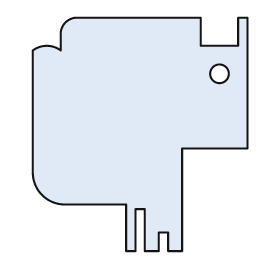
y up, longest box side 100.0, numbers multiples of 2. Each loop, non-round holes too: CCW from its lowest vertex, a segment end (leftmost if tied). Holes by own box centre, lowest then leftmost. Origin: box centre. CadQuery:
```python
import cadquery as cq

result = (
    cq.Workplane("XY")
    .moveTo(-6.0, -50.0)
    .lineTo(-2.0, -50.0)
    .lineTo(-2.0, -32.0)
    .lineTo(2.0, -32.0)
    .lineTo(2.0, -50.0)
    .lineTo(8.0, -50.0)
    .lineTo(8.0, -42.0)
    .lineTo(12.0, -42.0)
    .lineTo(12.0, -50.0)
    .lineTo(18.0, -50.0)
    .lineTo(18.0, -6.0)
    .lineTo(46.0, -6.0)
    .lineTo(46.0, 50.0)
    .lineTo(42.0, 50.0)
    .lineTo(42.0, 38.0)
    .lineTo(26.0, 38.0)
    .lineTo(26.0, 50.0)
    .lineTo(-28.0, 50.0)
    .threePointArc((-32.0, 48.0), (-34.0, 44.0))
    .lineTo(-34.0, 36.0)
    .threePointArc((-40.0, 38.0), (-46.0, 36.0))
    .lineTo(-46.0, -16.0)
    .threePointArc((-42.0, -26.0), (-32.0, -30.0))
    .lineTo(-6.0, -30.0)
    .close()
    .moveTo(34.0, 26.0)
    .circle(4.0)
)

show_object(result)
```